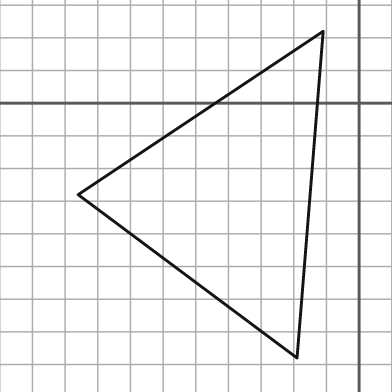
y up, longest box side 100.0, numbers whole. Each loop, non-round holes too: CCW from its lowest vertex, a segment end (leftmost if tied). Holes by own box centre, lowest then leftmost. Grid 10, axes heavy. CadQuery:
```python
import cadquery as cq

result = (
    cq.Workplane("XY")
    .moveTo(-19.0, -78.0)
    .lineTo(-11.0, 22.0)
    .lineTo(-86.0, -28.0)
    .close()
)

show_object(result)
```